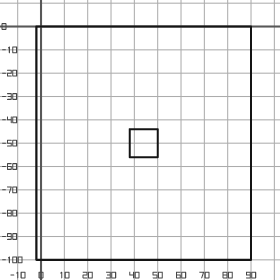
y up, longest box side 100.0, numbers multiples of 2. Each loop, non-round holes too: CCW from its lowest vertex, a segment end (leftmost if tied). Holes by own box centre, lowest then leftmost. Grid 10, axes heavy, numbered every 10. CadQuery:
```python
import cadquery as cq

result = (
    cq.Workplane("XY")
    .moveTo(-2.0, -100.0)
    .lineTo(90.0, -100.0)
    .lineTo(90.0, 0.0)
    .lineTo(-2.0, 0.0)
    .close()
    .moveTo(38.0, -56.0)
    .lineTo(50.0, -56.0)
    .lineTo(50.0, -44.0)
    .lineTo(38.0, -44.0)
    .close()
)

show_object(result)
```